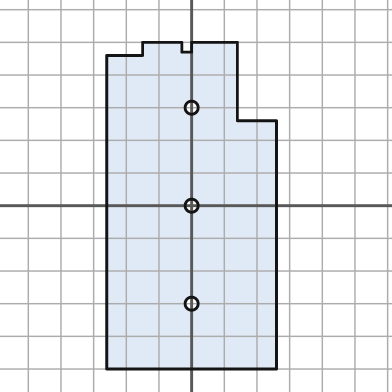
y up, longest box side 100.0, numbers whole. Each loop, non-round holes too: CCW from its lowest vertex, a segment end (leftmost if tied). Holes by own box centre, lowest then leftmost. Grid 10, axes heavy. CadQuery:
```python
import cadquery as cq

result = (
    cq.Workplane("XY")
    .moveTo(-26.0, -50.0)
    .lineTo(26.0, -50.0)
    .lineTo(26.0, 26.0)
    .lineTo(14.0, 26.0)
    .lineTo(14.0, 50.0)
    .lineTo(0.0, 50.0)
    .lineTo(0.0, 47.0)
    .lineTo(-3.0, 47.0)
    .lineTo(-3.0, 50.0)
    .lineTo(-15.0, 50.0)
    .lineTo(-15.0, 46.0)
    .lineTo(-26.0, 46.0)
    .close()
    .moveTo(0.0, -30.0)
    .circle(2.0)
    .moveTo(0.0, 0.0)
    .circle(2.0)
    .moveTo(0.0, 30.0)
    .circle(2.0)
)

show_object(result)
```